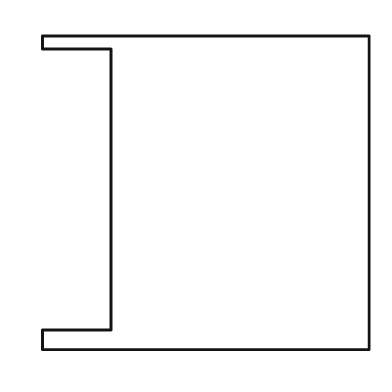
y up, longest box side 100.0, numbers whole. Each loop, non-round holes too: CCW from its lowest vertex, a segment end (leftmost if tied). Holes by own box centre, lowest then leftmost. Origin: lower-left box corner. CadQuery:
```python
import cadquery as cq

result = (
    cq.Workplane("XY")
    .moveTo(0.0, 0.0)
    .lineTo(100.0, 0.0)
    .lineTo(100.0, 96.0)
    .lineTo(0.0, 96.0)
    .lineTo(0.0, 92.0)
    .lineTo(21.0, 92.0)
    .lineTo(21.0, 6.0)
    .lineTo(0.0, 6.0)
    .close()
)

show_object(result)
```